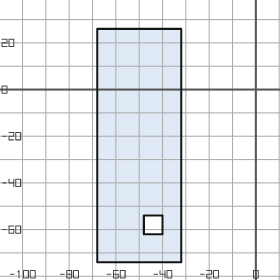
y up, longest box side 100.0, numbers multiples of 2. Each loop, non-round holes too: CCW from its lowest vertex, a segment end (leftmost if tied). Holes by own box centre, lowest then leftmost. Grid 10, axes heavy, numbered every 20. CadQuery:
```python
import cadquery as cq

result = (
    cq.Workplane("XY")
    .moveTo(-68.0, -74.0)
    .lineTo(-32.0, -74.0)
    .lineTo(-32.0, 26.0)
    .lineTo(-68.0, 26.0)
    .close()
    .moveTo(-48.0, -62.0)
    .lineTo(-40.0, -62.0)
    .lineTo(-40.0, -54.0)
    .lineTo(-48.0, -54.0)
    .close()
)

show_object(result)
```